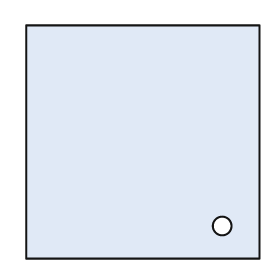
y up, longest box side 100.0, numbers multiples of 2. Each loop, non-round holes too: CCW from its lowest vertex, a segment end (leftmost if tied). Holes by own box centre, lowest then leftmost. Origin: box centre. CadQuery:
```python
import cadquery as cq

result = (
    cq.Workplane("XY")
    .moveTo(-50.0, -50.0)
    .lineTo(50.0, -50.0)
    .lineTo(50.0, 50.0)
    .lineTo(-50.0, 50.0)
    .close()
    .moveTo(34.0, -36.0)
    .circle(4.0)
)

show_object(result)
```